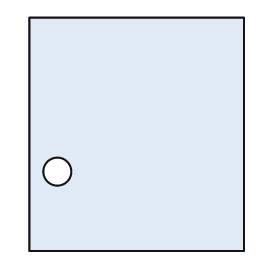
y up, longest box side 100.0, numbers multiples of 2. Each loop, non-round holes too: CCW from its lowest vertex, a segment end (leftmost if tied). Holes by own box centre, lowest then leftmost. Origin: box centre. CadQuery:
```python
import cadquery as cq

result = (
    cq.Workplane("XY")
    .moveTo(-46.0, -50.0)
    .lineTo(46.0, -50.0)
    .lineTo(46.0, 50.0)
    .lineTo(-46.0, 50.0)
    .close()
    .moveTo(-34.0, -16.0)
    .circle(6.0)
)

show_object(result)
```